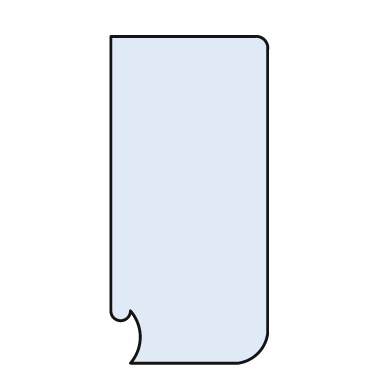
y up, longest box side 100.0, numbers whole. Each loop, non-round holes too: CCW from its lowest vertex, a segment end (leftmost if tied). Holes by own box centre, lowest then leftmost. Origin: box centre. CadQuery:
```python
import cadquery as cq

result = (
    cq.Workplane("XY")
    .moveTo(-18.0, -50.0)
    .lineTo(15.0, -50.0)
    .threePointArc((21.0, -47.0), (24.0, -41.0))
    .lineTo(24.0, 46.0)
    .threePointArc((23.0, 49.0), (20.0, 50.0))
    .lineTo(-24.0, 50.0)
    .lineTo(-24.0, -34.0)
    .threePointArc((-21.0, -37.0), (-18.0, -34.0))
    .threePointArc((-15.0, -42.0), (-18.0, -50.0))
    .close()
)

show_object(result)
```